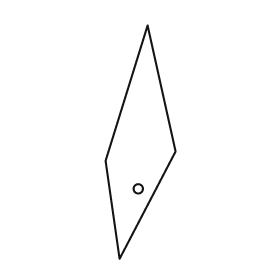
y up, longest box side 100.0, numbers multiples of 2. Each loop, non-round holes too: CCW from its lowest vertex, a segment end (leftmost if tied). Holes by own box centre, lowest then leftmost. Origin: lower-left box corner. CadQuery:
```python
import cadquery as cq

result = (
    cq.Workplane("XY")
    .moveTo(6.0, 0.0)
    .lineTo(30.0, 46.0)
    .lineTo(18.0, 100.0)
    .lineTo(0.0, 42.0)
    .close()
    .moveTo(14.0, 30.0)
    .circle(2.0)
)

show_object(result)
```